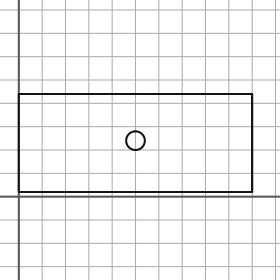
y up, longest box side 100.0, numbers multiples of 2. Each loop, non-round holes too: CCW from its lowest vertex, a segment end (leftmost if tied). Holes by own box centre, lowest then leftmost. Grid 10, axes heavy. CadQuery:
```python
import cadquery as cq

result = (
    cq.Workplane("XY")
    .moveTo(0.0, 2.0)
    .lineTo(100.0, 2.0)
    .lineTo(100.0, 44.0)
    .lineTo(0.0, 44.0)
    .close()
    .moveTo(50.0, 24.0)
    .circle(4.0)
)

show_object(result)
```